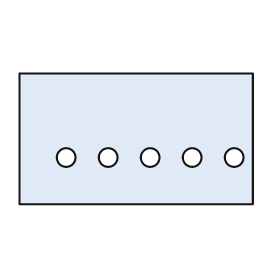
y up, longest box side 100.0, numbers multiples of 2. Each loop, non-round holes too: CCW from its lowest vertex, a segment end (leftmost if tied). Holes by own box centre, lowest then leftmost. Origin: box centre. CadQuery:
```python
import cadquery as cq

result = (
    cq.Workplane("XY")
    .moveTo(-50.0, -28.0)
    .lineTo(50.0, -28.0)
    .lineTo(50.0, 28.0)
    .lineTo(-50.0, 28.0)
    .close()
    .moveTo(-30.0, -8.0)
    .circle(4.0)
    .moveTo(-12.0, -8.0)
    .circle(4.0)
    .moveTo(6.0, -8.0)
    .circle(4.0)
    .moveTo(24.0, -8.0)
    .circle(4.0)
    .moveTo(42.0, -8.0)
    .circle(4.0)
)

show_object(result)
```